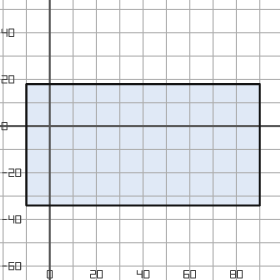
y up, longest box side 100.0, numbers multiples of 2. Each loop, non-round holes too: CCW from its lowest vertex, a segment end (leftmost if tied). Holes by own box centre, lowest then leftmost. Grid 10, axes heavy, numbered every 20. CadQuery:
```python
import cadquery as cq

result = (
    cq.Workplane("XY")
    .moveTo(-10.0, -34.0)
    .lineTo(90.0, -34.0)
    .lineTo(90.0, 18.0)
    .lineTo(-10.0, 18.0)
    .close()
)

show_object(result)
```